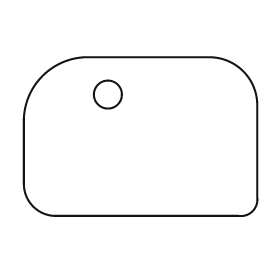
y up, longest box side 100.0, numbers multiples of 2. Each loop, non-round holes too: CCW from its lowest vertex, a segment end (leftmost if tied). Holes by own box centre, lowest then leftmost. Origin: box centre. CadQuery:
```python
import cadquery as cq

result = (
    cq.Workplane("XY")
    .moveTo(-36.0, -34.0)
    .lineTo(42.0, -34.0)
    .threePointArc((48.0, -32.0), (50.0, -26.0))
    .lineTo(50.0, 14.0)
    .threePointArc((44.0, 28.0), (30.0, 34.0))
    .lineTo(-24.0, 34.0)
    .threePointArc((-42.0, 26.0), (-50.0, 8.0))
    .lineTo(-50.0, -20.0)
    .threePointArc((-46.0, -30.0), (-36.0, -34.0))
    .close()
    .moveTo(-14.0, 18.0)
    .circle(6.0)
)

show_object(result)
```